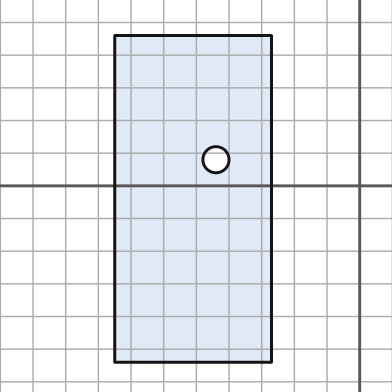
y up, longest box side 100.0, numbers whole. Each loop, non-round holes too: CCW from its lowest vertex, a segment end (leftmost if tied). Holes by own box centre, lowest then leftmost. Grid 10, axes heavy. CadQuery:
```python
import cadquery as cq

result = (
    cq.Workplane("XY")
    .moveTo(-75.0, -54.0)
    .lineTo(-27.0, -54.0)
    .lineTo(-27.0, 46.0)
    .lineTo(-75.0, 46.0)
    .close()
    .moveTo(-44.0, 8.0)
    .circle(4.0)
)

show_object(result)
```